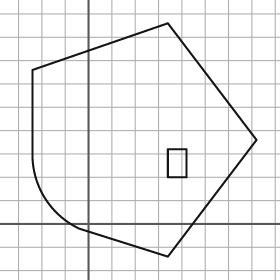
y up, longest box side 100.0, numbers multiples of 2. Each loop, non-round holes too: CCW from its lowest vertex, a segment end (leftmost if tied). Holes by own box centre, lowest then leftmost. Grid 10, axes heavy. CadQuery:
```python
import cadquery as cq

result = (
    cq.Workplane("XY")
    .moveTo(34.0, -14.0)
    .lineTo(72.0, 36.0)
    .lineTo(34.0, 86.0)
    .lineTo(-24.0, 66.0)
    .lineTo(-24.0, 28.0)
    .threePointArc((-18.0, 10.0), (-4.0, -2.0))
    .close()
    .moveTo(34.0, 20.0)
    .lineTo(42.0, 20.0)
    .lineTo(42.0, 32.0)
    .lineTo(34.0, 32.0)
    .close()
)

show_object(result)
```